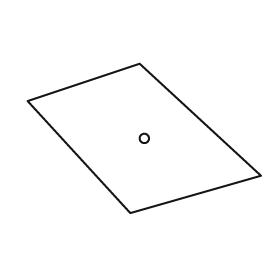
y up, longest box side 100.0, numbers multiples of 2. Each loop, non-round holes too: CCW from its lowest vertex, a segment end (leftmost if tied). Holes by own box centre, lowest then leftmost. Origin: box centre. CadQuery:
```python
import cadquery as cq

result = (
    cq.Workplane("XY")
    .moveTo(-6.0, -32.0)
    .lineTo(50.0, -16.0)
    .lineTo(-2.0, 32.0)
    .lineTo(-50.0, 16.0)
    .close()
    .moveTo(0.0, 0.0)
    .circle(2.0)
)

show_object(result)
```